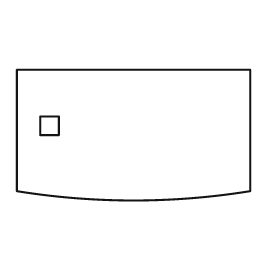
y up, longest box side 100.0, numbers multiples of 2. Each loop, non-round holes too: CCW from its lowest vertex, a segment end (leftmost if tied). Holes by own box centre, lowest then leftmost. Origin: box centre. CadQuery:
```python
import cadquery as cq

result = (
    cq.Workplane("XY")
    .moveTo(-50.0, -24.0)
    .threePointArc((0.0, -28.0), (50.0, -24.0))
    .lineTo(50.0, 28.0)
    .lineTo(-50.0, 28.0)
    .close()
    .moveTo(-40.0, 0.0)
    .lineTo(-32.0, 0.0)
    .lineTo(-32.0, 8.0)
    .lineTo(-40.0, 8.0)
    .close()
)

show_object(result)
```